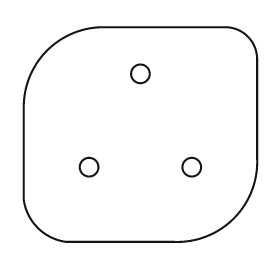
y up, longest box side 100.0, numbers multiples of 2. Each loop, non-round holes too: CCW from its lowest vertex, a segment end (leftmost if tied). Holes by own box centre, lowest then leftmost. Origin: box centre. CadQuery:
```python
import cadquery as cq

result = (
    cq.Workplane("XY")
    .moveTo(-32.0, -46.0)
    .lineTo(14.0, -46.0)
    .threePointArc((40.0, -36.0), (50.0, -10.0))
    .lineTo(50.0, 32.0)
    .threePointArc((46.0, 42.0), (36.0, 46.0))
    .lineTo(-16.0, 46.0)
    .threePointArc((-40.0, 36.0), (-50.0, 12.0))
    .lineTo(-50.0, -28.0)
    .threePointArc((-44.0, -40.0), (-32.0, -46.0))
    .close()
    .moveTo(-22.0, -14.0)
    .circle(4.0)
    .moveTo(22.0, -14.0)
    .circle(4.0)
    .moveTo(0.0, 26.0)
    .circle(4.0)
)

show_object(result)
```